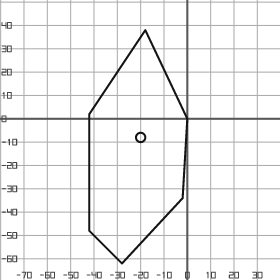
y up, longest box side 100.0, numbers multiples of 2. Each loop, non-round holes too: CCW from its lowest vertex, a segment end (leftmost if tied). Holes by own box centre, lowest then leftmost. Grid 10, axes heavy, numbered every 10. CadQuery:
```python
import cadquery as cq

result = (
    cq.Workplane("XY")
    .moveTo(-28.0, -62.0)
    .lineTo(-2.0, -34.0)
    .lineTo(0.0, 0.0)
    .lineTo(-18.0, 38.0)
    .lineTo(-42.0, 2.0)
    .lineTo(-42.0, -48.0)
    .close()
    .moveTo(-20.0, -8.0)
    .circle(2.0)
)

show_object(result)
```